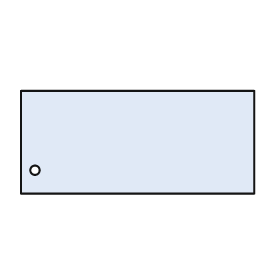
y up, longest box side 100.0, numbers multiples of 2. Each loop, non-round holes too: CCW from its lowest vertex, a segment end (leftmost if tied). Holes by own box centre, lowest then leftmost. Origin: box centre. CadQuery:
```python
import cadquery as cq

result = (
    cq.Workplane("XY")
    .moveTo(-50.0, -22.0)
    .lineTo(50.0, -22.0)
    .lineTo(50.0, 22.0)
    .lineTo(-50.0, 22.0)
    .close()
    .moveTo(-44.0, -12.0)
    .circle(2.0)
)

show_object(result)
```